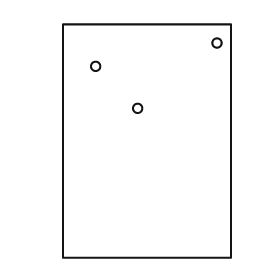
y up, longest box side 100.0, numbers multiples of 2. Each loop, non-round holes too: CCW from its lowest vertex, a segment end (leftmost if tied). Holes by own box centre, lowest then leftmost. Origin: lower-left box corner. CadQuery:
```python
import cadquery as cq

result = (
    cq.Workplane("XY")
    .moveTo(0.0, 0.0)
    .lineTo(72.0, 0.0)
    .lineTo(72.0, 100.0)
    .lineTo(0.0, 100.0)
    .close()
    .moveTo(32.0, 64.0)
    .circle(2.0)
    .moveTo(14.0, 82.0)
    .circle(2.0)
    .moveTo(66.0, 92.0)
    .circle(2.0)
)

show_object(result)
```